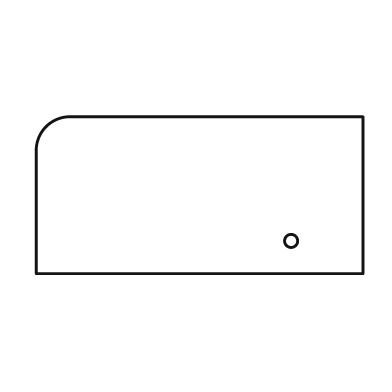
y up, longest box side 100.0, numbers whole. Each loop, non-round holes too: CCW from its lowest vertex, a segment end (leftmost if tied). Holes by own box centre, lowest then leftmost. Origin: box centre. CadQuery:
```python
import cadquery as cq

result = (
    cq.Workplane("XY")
    .moveTo(-50.0, -24.0)
    .lineTo(50.0, -24.0)
    .lineTo(50.0, 24.0)
    .lineTo(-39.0, 24.0)
    .threePointArc((-47.0, 21.0), (-50.0, 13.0))
    .close()
    .moveTo(28.0, -14.0)
    .circle(2.0)
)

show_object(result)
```